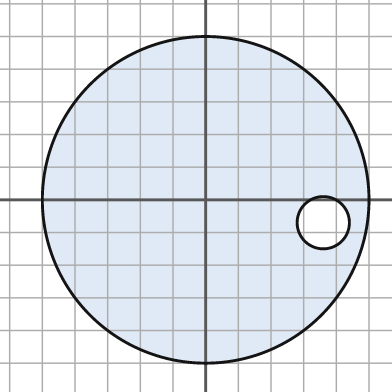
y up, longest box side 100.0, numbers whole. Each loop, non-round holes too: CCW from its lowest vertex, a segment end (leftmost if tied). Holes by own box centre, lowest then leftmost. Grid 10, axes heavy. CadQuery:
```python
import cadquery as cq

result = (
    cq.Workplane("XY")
    .moveTo(0.0, 0.0)
    .circle(50.0)
    .moveTo(36.0, -7.0)
    .circle(8.0)
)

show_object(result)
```